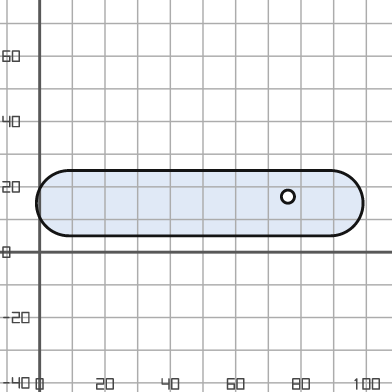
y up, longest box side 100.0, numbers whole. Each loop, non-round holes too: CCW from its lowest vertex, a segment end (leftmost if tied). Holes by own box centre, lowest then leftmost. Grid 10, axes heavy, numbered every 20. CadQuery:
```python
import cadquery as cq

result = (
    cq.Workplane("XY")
    .moveTo(9.0, 5.0)
    .lineTo(89.0, 5.0)
    .threePointArc((99.0, 15.0), (89.0, 25.0))
    .lineTo(9.0, 25.0)
    .threePointArc((-1.0, 15.0), (9.0, 5.0))
    .close()
    .moveTo(76.0, 17.0)
    .circle(2.0)
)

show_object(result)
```